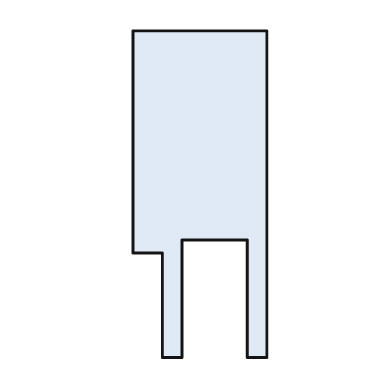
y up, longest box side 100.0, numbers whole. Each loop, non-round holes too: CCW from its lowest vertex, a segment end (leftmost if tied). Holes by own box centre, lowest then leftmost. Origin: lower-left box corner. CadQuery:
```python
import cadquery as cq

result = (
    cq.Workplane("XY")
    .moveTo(9.0, 0.0)
    .lineTo(15.0, 0.0)
    .lineTo(15.0, 36.0)
    .lineTo(35.0, 36.0)
    .lineTo(35.0, 0.0)
    .lineTo(41.0, 0.0)
    .lineTo(41.0, 100.0)
    .lineTo(0.0, 100.0)
    .lineTo(0.0, 32.0)
    .lineTo(9.0, 32.0)
    .close()
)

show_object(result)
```